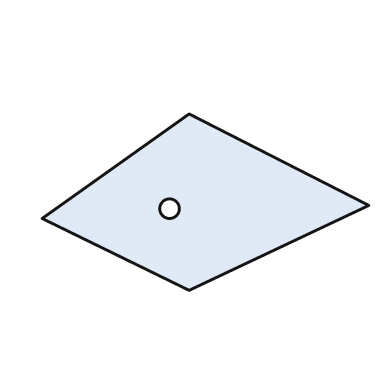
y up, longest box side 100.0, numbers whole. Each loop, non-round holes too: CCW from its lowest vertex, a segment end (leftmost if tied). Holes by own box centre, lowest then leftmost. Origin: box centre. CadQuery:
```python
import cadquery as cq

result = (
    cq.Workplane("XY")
    .moveTo(-5.0, -27.0)
    .lineTo(50.0, -1.0)
    .lineTo(-5.0, 27.0)
    .lineTo(-50.0, -5.0)
    .close()
    .moveTo(-11.0, -2.0)
    .circle(3.0)
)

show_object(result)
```